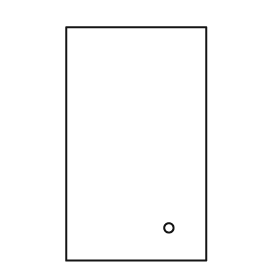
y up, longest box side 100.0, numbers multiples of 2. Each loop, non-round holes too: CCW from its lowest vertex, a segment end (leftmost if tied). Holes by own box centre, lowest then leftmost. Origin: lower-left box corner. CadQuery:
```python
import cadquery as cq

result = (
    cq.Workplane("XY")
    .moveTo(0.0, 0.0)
    .lineTo(60.0, 0.0)
    .lineTo(60.0, 100.0)
    .lineTo(0.0, 100.0)
    .close()
    .moveTo(44.0, 14.0)
    .circle(2.0)
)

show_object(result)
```